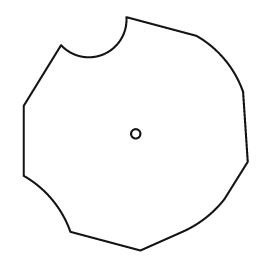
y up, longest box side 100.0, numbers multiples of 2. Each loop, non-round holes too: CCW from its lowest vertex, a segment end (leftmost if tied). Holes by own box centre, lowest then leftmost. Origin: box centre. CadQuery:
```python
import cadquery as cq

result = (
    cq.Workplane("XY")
    .moveTo(2.0, -50.0)
    .lineTo(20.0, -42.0)
    .threePointArc((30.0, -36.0), (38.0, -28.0))
    .lineTo(48.0, -12.0)
    .lineTo(46.0, 18.0)
    .threePointArc((38.0, 32.0), (26.0, 42.0))
    .lineTo(-4.0, 50.0)
    .threePointArc((-14.0, 34.0), (-32.0, 38.0))
    .lineTo(-48.0, 12.0)
    .lineTo(-48.0, -18.0)
    .threePointArc((-36.0, -28.0), (-28.0, -42.0))
    .close()
    .moveTo(0.0, 0.0)
    .circle(2.0)
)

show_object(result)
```